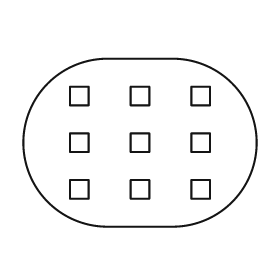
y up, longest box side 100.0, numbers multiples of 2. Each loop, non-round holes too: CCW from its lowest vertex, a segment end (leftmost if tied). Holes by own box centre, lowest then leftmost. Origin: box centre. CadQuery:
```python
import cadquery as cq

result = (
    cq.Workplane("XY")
    .moveTo(-14.0, -36.0)
    .lineTo(14.0, -36.0)
    .threePointArc((50.0, 0.0), (14.0, 36.0))
    .lineTo(-14.0, 36.0)
    .threePointArc((-50.0, 0.0), (-14.0, -36.0))
    .close()
    .moveTo(-30.0, -24.0)
    .lineTo(-22.0, -24.0)
    .lineTo(-22.0, -16.0)
    .lineTo(-30.0, -16.0)
    .close()
    .moveTo(-4.0, -24.0)
    .lineTo(4.0, -24.0)
    .lineTo(4.0, -16.0)
    .lineTo(-4.0, -16.0)
    .close()
    .moveTo(22.0, -24.0)
    .lineTo(30.0, -24.0)
    .lineTo(30.0, -16.0)
    .lineTo(22.0, -16.0)
    .close()
    .moveTo(-30.0, -4.0)
    .lineTo(-22.0, -4.0)
    .lineTo(-22.0, 4.0)
    .lineTo(-30.0, 4.0)
    .close()
    .moveTo(-4.0, -4.0)
    .lineTo(4.0, -4.0)
    .lineTo(4.0, 4.0)
    .lineTo(-4.0, 4.0)
    .close()
    .moveTo(22.0, -4.0)
    .lineTo(30.0, -4.0)
    .lineTo(30.0, 4.0)
    .lineTo(22.0, 4.0)
    .close()
    .moveTo(-30.0, 16.0)
    .lineTo(-22.0, 16.0)
    .lineTo(-22.0, 24.0)
    .lineTo(-30.0, 24.0)
    .close()
    .moveTo(-4.0, 16.0)
    .lineTo(4.0, 16.0)
    .lineTo(4.0, 24.0)
    .lineTo(-4.0, 24.0)
    .close()
    .moveTo(22.0, 16.0)
    .lineTo(30.0, 16.0)
    .lineTo(30.0, 24.0)
    .lineTo(22.0, 24.0)
    .close()
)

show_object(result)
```